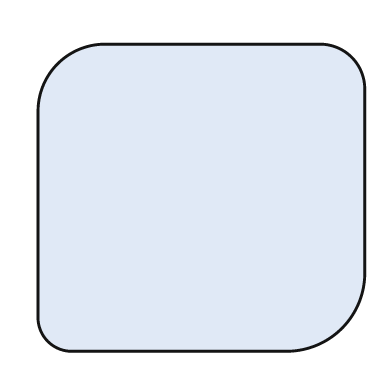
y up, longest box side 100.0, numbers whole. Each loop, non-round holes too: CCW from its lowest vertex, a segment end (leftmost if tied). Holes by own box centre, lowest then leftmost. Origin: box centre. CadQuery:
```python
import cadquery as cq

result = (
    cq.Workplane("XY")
    .moveTo(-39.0, -47.0)
    .lineTo(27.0, -47.0)
    .threePointArc((43.0, -40.0), (50.0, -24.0))
    .lineTo(50.0, 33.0)
    .threePointArc((46.0, 43.0), (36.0, 47.0))
    .lineTo(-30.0, 47.0)
    .threePointArc((-44.0, 41.0), (-50.0, 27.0))
    .lineTo(-50.0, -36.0)
    .threePointArc((-47.0, -44.0), (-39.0, -47.0))
    .close()
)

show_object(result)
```